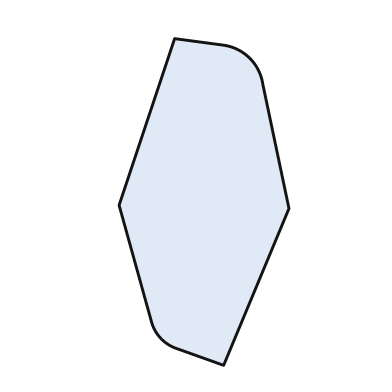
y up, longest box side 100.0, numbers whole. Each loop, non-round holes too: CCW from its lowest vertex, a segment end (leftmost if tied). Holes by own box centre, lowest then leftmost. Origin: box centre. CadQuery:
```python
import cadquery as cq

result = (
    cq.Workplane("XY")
    .moveTo(6.0, -50.0)
    .lineTo(26.0, -2.0)
    .lineTo(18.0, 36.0)
    .threePointArc((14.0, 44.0), (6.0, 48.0))
    .lineTo(-9.0, 50.0)
    .lineTo(-26.0, -1.0)
    .lineTo(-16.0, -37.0)
    .threePointArc((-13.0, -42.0), (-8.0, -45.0))
    .close()
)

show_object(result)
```